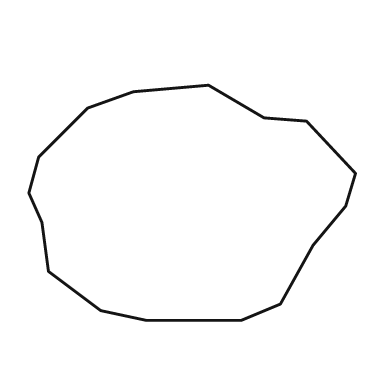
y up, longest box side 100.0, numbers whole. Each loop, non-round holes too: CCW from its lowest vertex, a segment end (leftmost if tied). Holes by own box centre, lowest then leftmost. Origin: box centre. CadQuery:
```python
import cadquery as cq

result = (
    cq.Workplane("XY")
    .moveTo(-14.0, -36.0)
    .lineTo(15.0, -36.0)
    .lineTo(27.0, -31.0)
    .lineTo(37.0, -13.0)
    .lineTo(47.0, -1.0)
    .lineTo(50.0, 9.0)
    .lineTo(35.0, 25.0)
    .lineTo(22.0, 26.0)
    .lineTo(5.0, 36.0)
    .lineTo(-18.0, 34.0)
    .lineTo(-32.0, 29.0)
    .lineTo(-47.0, 14.0)
    .lineTo(-50.0, 3.0)
    .lineTo(-46.0, -6.0)
    .lineTo(-44.0, -21.0)
    .lineTo(-28.0, -33.0)
    .close()
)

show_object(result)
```